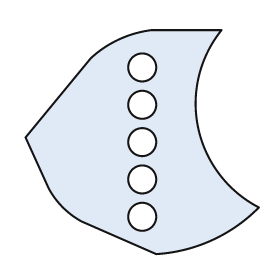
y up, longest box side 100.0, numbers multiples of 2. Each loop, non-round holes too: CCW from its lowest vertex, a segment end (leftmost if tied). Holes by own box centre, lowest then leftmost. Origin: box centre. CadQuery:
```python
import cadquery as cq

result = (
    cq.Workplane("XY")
    .moveTo(6.0, -48.0)
    .threePointArc((30.0, -42.0), (50.0, -28.0))
    .threePointArc((24.0, 6.0), (34.0, 48.0))
    .lineTo(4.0, 48.0)
    .threePointArc((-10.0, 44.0), (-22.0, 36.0))
    .lineTo(-50.0, 2.0)
    .lineTo(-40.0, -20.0)
    .threePointArc((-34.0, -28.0), (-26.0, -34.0))
    .close()
    .moveTo(0.0, -32.0)
    .circle(6.0)
    .moveTo(0.0, -16.0)
    .circle(6.0)
    .moveTo(0.0, 0.0)
    .circle(6.0)
    .moveTo(0.0, 16.0)
    .circle(6.0)
    .moveTo(0.0, 32.0)
    .circle(6.0)
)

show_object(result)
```